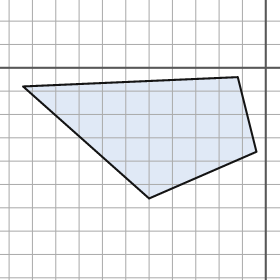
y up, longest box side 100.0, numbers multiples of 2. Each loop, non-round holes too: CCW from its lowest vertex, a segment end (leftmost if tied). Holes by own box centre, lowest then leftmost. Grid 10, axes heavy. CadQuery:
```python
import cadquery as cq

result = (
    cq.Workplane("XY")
    .moveTo(-50.0, -56.0)
    .lineTo(-4.0, -36.0)
    .lineTo(-12.0, -4.0)
    .lineTo(-104.0, -8.0)
    .close()
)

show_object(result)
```